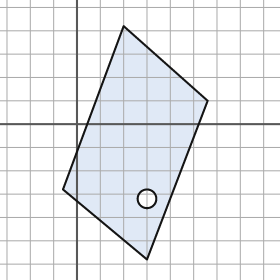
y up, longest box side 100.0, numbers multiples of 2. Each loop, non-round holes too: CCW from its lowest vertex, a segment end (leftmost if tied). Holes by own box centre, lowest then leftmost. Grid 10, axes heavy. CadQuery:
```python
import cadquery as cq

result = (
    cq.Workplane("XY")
    .moveTo(30.0, -58.0)
    .lineTo(56.0, 10.0)
    .lineTo(20.0, 42.0)
    .lineTo(-6.0, -28.0)
    .close()
    .moveTo(30.0, -32.0)
    .circle(4.0)
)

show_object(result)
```